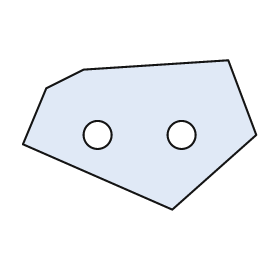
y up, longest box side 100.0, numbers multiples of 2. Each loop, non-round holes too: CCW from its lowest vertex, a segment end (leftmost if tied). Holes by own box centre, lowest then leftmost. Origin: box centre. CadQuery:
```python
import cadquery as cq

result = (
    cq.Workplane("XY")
    .moveTo(14.0, -32.0)
    .lineTo(50.0, 0.0)
    .lineTo(38.0, 32.0)
    .lineTo(-24.0, 28.0)
    .lineTo(-40.0, 20.0)
    .lineTo(-50.0, -4.0)
    .close()
    .moveTo(-18.0, 0.0)
    .circle(6.0)
    .moveTo(18.0, 0.0)
    .circle(6.0)
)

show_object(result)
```